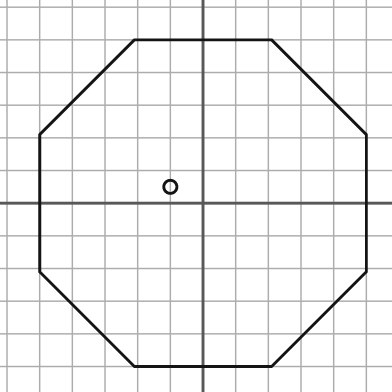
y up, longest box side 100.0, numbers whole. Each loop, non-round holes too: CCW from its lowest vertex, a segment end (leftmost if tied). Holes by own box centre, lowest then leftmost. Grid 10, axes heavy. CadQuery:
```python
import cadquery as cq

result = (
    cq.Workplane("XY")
    .moveTo(-21.0, -50.0)
    .lineTo(21.0, -50.0)
    .lineTo(50.0, -21.0)
    .lineTo(50.0, 21.0)
    .lineTo(21.0, 50.0)
    .lineTo(-21.0, 50.0)
    .lineTo(-50.0, 21.0)
    .lineTo(-50.0, -21.0)
    .close()
    .moveTo(-10.0, 5.0)
    .circle(2.0)
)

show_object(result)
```